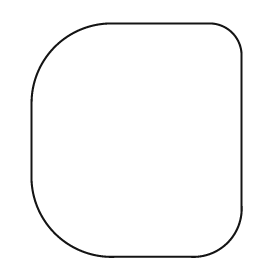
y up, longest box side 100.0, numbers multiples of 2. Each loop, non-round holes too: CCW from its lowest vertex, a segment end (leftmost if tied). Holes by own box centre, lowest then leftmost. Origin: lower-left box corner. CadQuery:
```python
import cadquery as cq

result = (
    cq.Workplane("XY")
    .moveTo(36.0, 0.0)
    .lineTo(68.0, 0.0)
    .threePointArc((84.0, 6.0), (90.0, 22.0))
    .lineTo(90.0, 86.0)
    .threePointArc((86.0, 96.0), (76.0, 100.0))
    .lineTo(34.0, 100.0)
    .threePointArc((10.0, 90.0), (0.0, 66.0))
    .lineTo(0.0, 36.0)
    .threePointArc((10.0, 10.0), (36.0, 0.0))
    .close()
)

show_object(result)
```